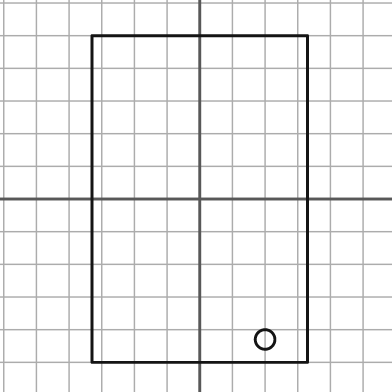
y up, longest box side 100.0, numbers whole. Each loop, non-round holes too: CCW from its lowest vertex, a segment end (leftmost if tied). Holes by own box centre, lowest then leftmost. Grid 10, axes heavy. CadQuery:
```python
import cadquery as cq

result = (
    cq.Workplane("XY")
    .moveTo(-33.0, -50.0)
    .lineTo(33.0, -50.0)
    .lineTo(33.0, 50.0)
    .lineTo(-33.0, 50.0)
    .close()
    .moveTo(20.0, -43.0)
    .circle(3.0)
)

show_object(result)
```